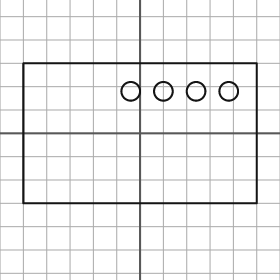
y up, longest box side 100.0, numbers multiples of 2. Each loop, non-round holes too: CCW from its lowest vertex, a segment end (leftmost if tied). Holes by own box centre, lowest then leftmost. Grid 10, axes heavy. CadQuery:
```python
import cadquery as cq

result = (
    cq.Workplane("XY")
    .moveTo(-50.0, -30.0)
    .lineTo(50.0, -30.0)
    .lineTo(50.0, 30.0)
    .lineTo(-50.0, 30.0)
    .close()
    .moveTo(-4.0, 18.0)
    .circle(4.0)
    .moveTo(10.0, 18.0)
    .circle(4.0)
    .moveTo(24.0, 18.0)
    .circle(4.0)
    .moveTo(38.0, 18.0)
    .circle(4.0)
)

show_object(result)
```